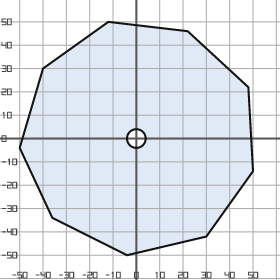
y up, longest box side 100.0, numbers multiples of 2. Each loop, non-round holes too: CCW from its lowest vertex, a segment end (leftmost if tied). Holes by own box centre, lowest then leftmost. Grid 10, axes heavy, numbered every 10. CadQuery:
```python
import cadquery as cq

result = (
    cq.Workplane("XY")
    .moveTo(-4.0, -50.0)
    .lineTo(30.0, -42.0)
    .lineTo(50.0, -14.0)
    .lineTo(48.0, 22.0)
    .lineTo(22.0, 46.0)
    .lineTo(-12.0, 50.0)
    .lineTo(-40.0, 30.0)
    .lineTo(-50.0, -4.0)
    .lineTo(-36.0, -34.0)
    .close()
    .moveTo(0.0, 0.0)
    .circle(4.0)
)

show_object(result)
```